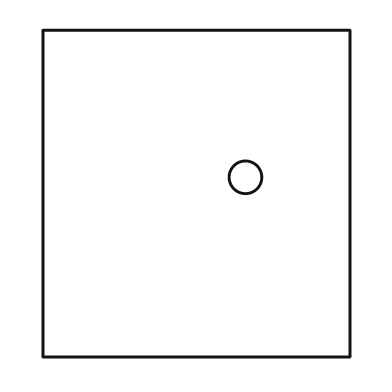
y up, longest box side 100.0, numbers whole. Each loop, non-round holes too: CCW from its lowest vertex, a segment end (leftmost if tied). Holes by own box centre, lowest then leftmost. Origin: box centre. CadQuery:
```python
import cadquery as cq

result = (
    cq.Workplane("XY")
    .moveTo(-47.0, -50.0)
    .lineTo(47.0, -50.0)
    .lineTo(47.0, 50.0)
    .lineTo(-47.0, 50.0)
    .close()
    .moveTo(15.0, 5.0)
    .circle(5.0)
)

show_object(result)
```